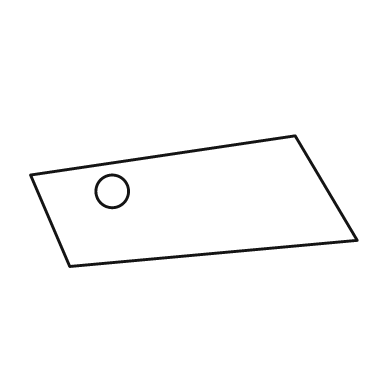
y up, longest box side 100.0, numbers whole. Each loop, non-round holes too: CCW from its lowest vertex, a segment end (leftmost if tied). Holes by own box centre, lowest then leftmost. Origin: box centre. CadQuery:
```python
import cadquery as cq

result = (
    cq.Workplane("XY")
    .moveTo(-38.0, -20.0)
    .lineTo(50.0, -12.0)
    .lineTo(31.0, 20.0)
    .lineTo(-50.0, 8.0)
    .close()
    .moveTo(-25.0, 3.0)
    .circle(5.0)
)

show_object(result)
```